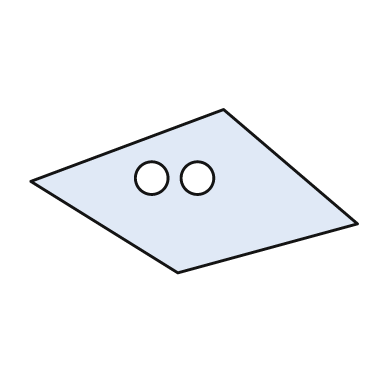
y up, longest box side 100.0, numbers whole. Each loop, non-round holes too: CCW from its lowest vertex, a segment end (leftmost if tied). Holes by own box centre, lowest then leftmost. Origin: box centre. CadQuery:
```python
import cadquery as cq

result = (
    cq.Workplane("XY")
    .moveTo(-5.0, -25.0)
    .lineTo(50.0, -10.0)
    .lineTo(9.0, 25.0)
    .lineTo(-50.0, 3.0)
    .close()
    .moveTo(-13.0, 4.0)
    .circle(5.0)
    .moveTo(1.0, 4.0)
    .circle(5.0)
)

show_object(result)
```